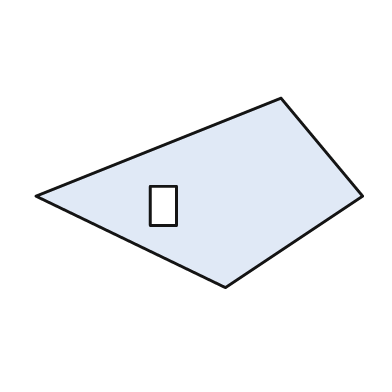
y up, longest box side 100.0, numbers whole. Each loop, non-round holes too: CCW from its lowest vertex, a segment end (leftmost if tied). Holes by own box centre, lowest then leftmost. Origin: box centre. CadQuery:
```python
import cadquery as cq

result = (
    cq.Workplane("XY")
    .moveTo(8.0, -29.0)
    .lineTo(50.0, -1.0)
    .lineTo(25.0, 29.0)
    .lineTo(-50.0, -1.0)
    .close()
    .moveTo(-15.0, -10.0)
    .lineTo(-7.0, -10.0)
    .lineTo(-7.0, 2.0)
    .lineTo(-15.0, 2.0)
    .close()
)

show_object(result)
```